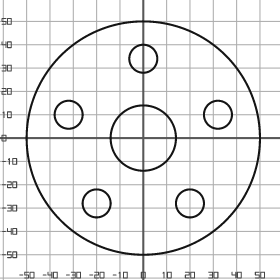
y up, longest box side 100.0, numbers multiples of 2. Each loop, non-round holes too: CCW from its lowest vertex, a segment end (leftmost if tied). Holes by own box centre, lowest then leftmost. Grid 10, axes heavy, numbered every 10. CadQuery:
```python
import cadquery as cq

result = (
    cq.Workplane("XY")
    .moveTo(0.0, 0.0)
    .circle(50.0)
    .moveTo(-20.0, -28.0)
    .circle(6.0)
    .moveTo(20.0, -28.0)
    .circle(6.0)
    .moveTo(0.0, 0.0)
    .circle(14.0)
    .moveTo(-32.0, 10.0)
    .circle(6.0)
    .moveTo(32.0, 10.0)
    .circle(6.0)
    .moveTo(0.0, 34.0)
    .circle(6.0)
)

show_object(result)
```